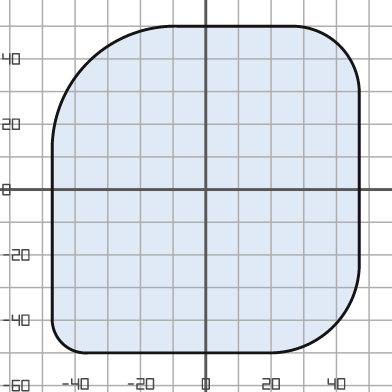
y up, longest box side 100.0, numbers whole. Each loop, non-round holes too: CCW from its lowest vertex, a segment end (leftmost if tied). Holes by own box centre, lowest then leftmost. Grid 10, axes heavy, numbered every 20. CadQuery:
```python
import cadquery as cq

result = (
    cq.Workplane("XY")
    .moveTo(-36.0, -50.0)
    .lineTo(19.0, -50.0)
    .threePointArc((39.0, -42.0), (47.0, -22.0))
    .lineTo(47.0, 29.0)
    .threePointArc((41.0, 44.0), (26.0, 50.0))
    .lineTo(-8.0, 50.0)
    .threePointArc((-36.0, 39.0), (-47.0, 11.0))
    .lineTo(-47.0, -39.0)
    .threePointArc((-44.0, -47.0), (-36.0, -50.0))
    .close()
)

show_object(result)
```